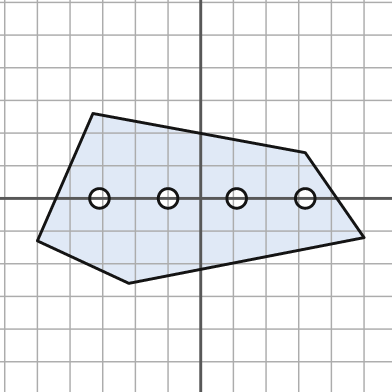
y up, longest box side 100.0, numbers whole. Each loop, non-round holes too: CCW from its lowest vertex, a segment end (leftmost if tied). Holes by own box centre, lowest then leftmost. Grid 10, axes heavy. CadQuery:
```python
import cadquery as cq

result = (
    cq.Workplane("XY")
    .moveTo(-22.0, -26.0)
    .lineTo(50.0, -12.0)
    .lineTo(32.0, 14.0)
    .lineTo(-33.0, 26.0)
    .lineTo(-50.0, -13.0)
    .close()
    .moveTo(-31.0, 0.0)
    .circle(3.0)
    .moveTo(-10.0, 0.0)
    .circle(3.0)
    .moveTo(11.0, 0.0)
    .circle(3.0)
    .moveTo(32.0, 0.0)
    .circle(3.0)
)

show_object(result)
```